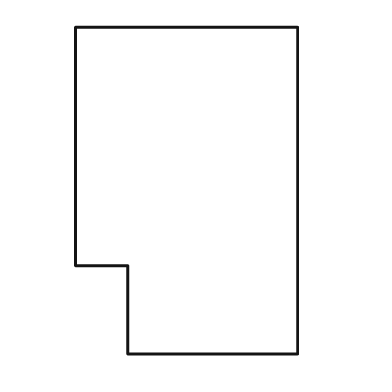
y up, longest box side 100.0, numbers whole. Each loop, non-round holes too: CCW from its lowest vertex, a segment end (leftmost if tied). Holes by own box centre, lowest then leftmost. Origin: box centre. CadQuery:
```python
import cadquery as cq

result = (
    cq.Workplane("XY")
    .moveTo(-18.0, -50.0)
    .lineTo(34.0, -50.0)
    .lineTo(34.0, 50.0)
    .lineTo(-34.0, 50.0)
    .lineTo(-34.0, -23.0)
    .lineTo(-18.0, -23.0)
    .close()
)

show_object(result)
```